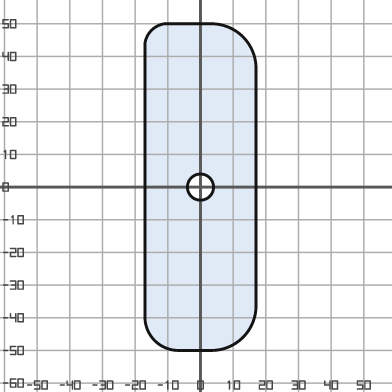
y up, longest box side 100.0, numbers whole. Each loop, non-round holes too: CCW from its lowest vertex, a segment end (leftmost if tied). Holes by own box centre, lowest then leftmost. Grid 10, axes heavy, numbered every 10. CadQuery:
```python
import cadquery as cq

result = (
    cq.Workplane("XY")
    .moveTo(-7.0, -50.0)
    .lineTo(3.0, -50.0)
    .threePointArc((13.0, -46.0), (17.0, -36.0))
    .lineTo(17.0, 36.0)
    .threePointArc((13.0, 46.0), (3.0, 50.0))
    .lineTo(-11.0, 50.0)
    .threePointArc((-15.0, 48.0), (-17.0, 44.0))
    .lineTo(-17.0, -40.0)
    .threePointArc((-14.0, -47.0), (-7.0, -50.0))
    .close()
    .moveTo(0.0, 0.0)
    .circle(4.0)
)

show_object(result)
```